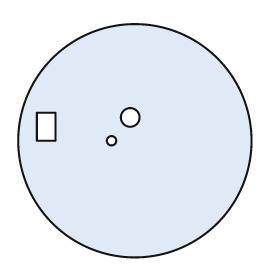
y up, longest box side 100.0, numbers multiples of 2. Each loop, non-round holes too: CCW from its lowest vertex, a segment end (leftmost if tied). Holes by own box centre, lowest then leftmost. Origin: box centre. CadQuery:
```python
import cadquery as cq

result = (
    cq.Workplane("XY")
    .moveTo(0.0, 0.0)
    .circle(50.0)
    .moveTo(-10.0, 0.0)
    .circle(2.0)
    .moveTo(-42.0, 0.0)
    .lineTo(-34.0, 0.0)
    .lineTo(-34.0, 12.0)
    .lineTo(-42.0, 12.0)
    .close()
    .moveTo(-2.0, 10.0)
    .circle(4.0)
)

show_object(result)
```